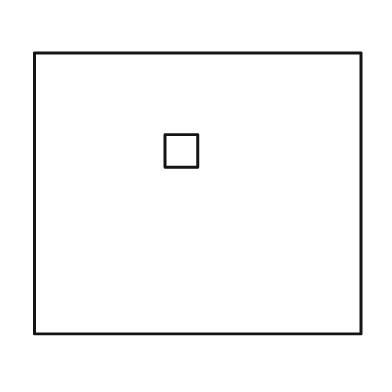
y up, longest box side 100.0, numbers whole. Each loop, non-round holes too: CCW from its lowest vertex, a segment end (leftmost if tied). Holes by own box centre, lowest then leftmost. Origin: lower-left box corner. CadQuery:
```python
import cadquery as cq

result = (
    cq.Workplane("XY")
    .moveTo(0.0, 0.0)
    .lineTo(100.0, 0.0)
    .lineTo(100.0, 86.0)
    .lineTo(0.0, 86.0)
    .close()
    .moveTo(40.0, 51.0)
    .lineTo(50.0, 51.0)
    .lineTo(50.0, 61.0)
    .lineTo(40.0, 61.0)
    .close()
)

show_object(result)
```